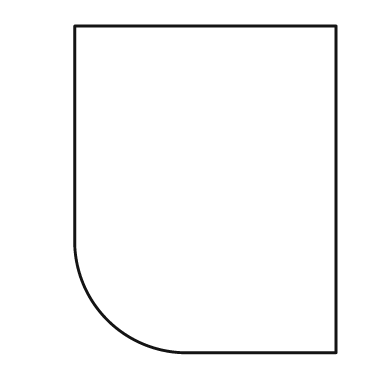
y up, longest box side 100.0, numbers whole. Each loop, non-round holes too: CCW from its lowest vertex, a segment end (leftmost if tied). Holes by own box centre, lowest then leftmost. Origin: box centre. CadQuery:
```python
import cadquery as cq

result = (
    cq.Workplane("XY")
    .moveTo(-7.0, -50.0)
    .lineTo(40.0, -50.0)
    .lineTo(40.0, 50.0)
    .lineTo(-40.0, 50.0)
    .lineTo(-40.0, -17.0)
    .threePointArc((-30.0, -40.0), (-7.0, -50.0))
    .close()
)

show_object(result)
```